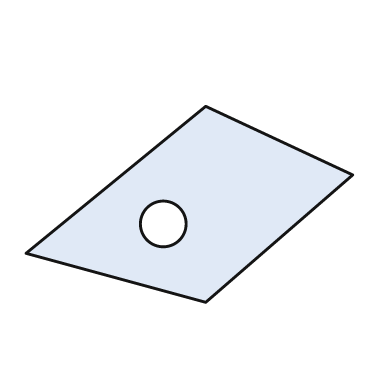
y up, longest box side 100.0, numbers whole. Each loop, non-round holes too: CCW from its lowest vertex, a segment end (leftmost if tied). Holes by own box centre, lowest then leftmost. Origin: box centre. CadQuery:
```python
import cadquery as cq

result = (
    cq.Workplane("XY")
    .moveTo(5.0, -30.0)
    .lineTo(50.0, 9.0)
    .lineTo(5.0, 30.0)
    .lineTo(-50.0, -15.0)
    .close()
    .moveTo(-8.0, -6.0)
    .circle(7.0)
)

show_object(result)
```